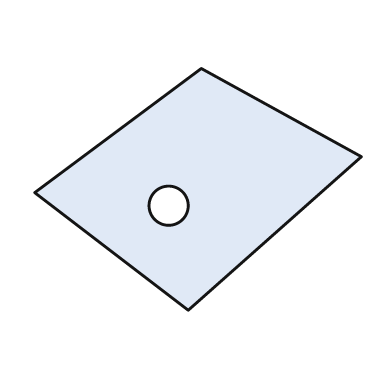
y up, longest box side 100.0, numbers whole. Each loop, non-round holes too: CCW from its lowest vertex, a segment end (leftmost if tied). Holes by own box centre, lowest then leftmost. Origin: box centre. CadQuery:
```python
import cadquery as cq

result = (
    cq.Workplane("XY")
    .moveTo(-3.0, -37.0)
    .lineTo(50.0, 10.0)
    .lineTo(1.0, 37.0)
    .lineTo(-50.0, -1.0)
    .close()
    .moveTo(-9.0, -5.0)
    .circle(6.0)
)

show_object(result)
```